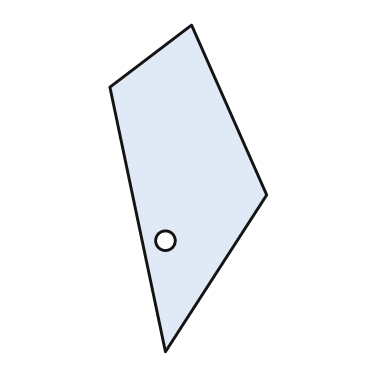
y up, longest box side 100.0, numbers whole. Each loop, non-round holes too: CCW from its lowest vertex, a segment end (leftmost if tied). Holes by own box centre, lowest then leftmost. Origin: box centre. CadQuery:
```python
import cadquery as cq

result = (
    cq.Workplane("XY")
    .moveTo(-7.0, -50.0)
    .lineTo(24.0, -2.0)
    .lineTo(1.0, 50.0)
    .lineTo(-24.0, 31.0)
    .close()
    .moveTo(-7.0, -16.0)
    .circle(3.0)
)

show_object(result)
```